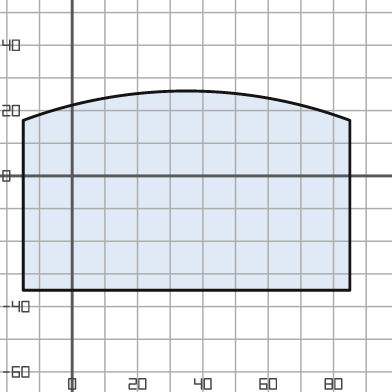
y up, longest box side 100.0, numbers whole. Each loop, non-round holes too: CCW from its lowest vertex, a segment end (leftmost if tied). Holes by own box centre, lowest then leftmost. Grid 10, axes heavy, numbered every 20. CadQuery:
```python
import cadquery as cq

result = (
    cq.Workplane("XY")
    .moveTo(-15.0, -35.0)
    .lineTo(85.0, -35.0)
    .lineTo(85.0, 17.0)
    .threePointArc((35.0, 26.0), (-15.0, 17.0))
    .close()
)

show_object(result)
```